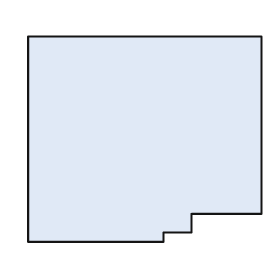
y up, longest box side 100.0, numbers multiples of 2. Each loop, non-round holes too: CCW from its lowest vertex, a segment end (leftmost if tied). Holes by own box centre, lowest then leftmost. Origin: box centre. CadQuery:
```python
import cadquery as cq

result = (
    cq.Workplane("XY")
    .moveTo(-50.0, -44.0)
    .lineTo(8.0, -44.0)
    .lineTo(8.0, -40.0)
    .lineTo(20.0, -40.0)
    .lineTo(20.0, -32.0)
    .lineTo(50.0, -32.0)
    .lineTo(50.0, 44.0)
    .lineTo(-50.0, 44.0)
    .close()
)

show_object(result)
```